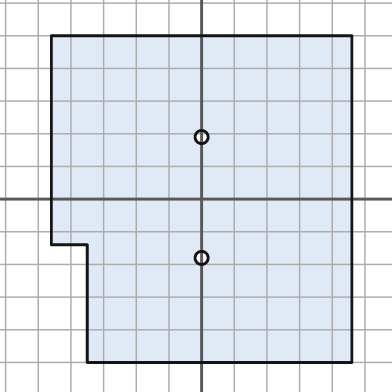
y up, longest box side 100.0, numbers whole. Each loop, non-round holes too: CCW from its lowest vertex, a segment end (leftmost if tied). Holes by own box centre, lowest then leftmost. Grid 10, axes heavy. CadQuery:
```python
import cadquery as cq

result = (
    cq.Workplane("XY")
    .moveTo(-35.0, -50.0)
    .lineTo(46.0, -50.0)
    .lineTo(46.0, 50.0)
    .lineTo(-46.0, 50.0)
    .lineTo(-46.0, -14.0)
    .lineTo(-35.0, -14.0)
    .close()
    .moveTo(0.0, -18.0)
    .circle(2.0)
    .moveTo(0.0, 19.0)
    .circle(2.0)
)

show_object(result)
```